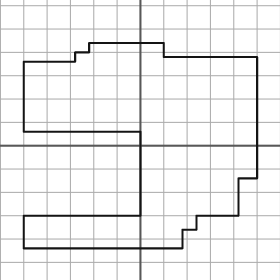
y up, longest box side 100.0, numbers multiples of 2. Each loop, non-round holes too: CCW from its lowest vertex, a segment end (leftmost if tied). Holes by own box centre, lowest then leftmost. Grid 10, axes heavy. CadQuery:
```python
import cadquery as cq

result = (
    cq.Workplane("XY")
    .moveTo(-50.0, -44.0)
    .lineTo(18.0, -44.0)
    .lineTo(18.0, -36.0)
    .lineTo(24.0, -36.0)
    .lineTo(24.0, -30.0)
    .lineTo(42.0, -30.0)
    .lineTo(42.0, -14.0)
    .lineTo(50.0, -14.0)
    .lineTo(50.0, 38.0)
    .lineTo(10.0, 38.0)
    .lineTo(10.0, 44.0)
    .lineTo(-22.0, 44.0)
    .lineTo(-22.0, 40.0)
    .lineTo(-28.0, 40.0)
    .lineTo(-28.0, 36.0)
    .lineTo(-50.0, 36.0)
    .lineTo(-50.0, 6.0)
    .lineTo(0.0, 6.0)
    .lineTo(0.0, -30.0)
    .lineTo(-50.0, -30.0)
    .close()
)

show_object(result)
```